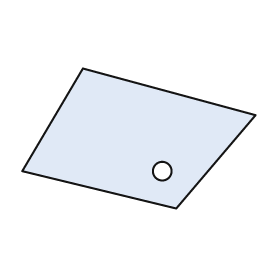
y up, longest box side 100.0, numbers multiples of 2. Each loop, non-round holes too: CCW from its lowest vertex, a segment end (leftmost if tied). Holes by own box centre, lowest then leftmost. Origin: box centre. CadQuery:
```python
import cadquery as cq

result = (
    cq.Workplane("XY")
    .moveTo(16.0, -30.0)
    .lineTo(50.0, 10.0)
    .lineTo(-24.0, 30.0)
    .lineTo(-50.0, -14.0)
    .close()
    .moveTo(10.0, -14.0)
    .circle(4.0)
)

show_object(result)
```